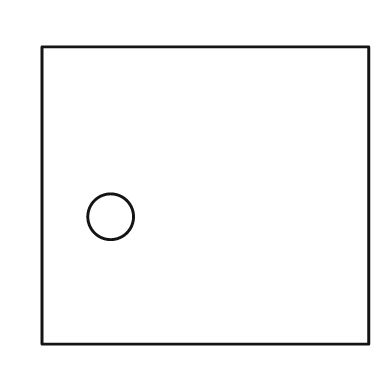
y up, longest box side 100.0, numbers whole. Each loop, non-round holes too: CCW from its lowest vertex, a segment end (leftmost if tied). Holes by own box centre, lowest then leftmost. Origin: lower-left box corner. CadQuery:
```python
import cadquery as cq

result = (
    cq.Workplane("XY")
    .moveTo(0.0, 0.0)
    .lineTo(100.0, 0.0)
    .lineTo(100.0, 91.0)
    .lineTo(0.0, 91.0)
    .close()
    .moveTo(21.0, 39.0)
    .circle(7.0)
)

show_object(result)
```